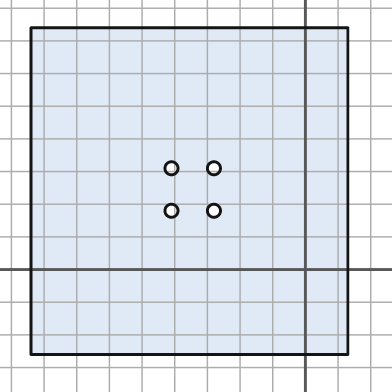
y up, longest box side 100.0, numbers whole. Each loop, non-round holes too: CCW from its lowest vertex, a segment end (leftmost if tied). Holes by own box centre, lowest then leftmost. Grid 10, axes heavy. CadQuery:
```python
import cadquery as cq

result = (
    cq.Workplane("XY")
    .moveTo(-84.0, -26.0)
    .lineTo(13.0, -26.0)
    .lineTo(13.0, 74.0)
    .lineTo(-84.0, 74.0)
    .close()
    .moveTo(-41.0, 18.0)
    .circle(2.0)
    .moveTo(-28.0, 18.0)
    .circle(2.0)
    .moveTo(-41.0, 31.0)
    .circle(2.0)
    .moveTo(-28.0, 31.0)
    .circle(2.0)
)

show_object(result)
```